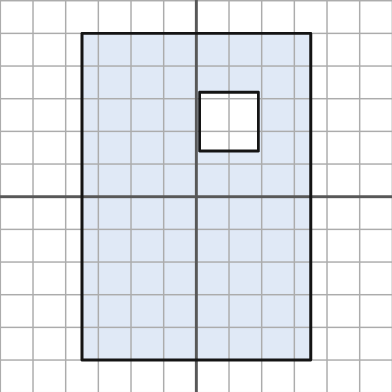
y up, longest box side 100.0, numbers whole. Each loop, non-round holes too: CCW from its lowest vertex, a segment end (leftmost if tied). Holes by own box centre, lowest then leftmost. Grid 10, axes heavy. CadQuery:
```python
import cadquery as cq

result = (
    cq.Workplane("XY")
    .moveTo(-35.0, -50.0)
    .lineTo(35.0, -50.0)
    .lineTo(35.0, 50.0)
    .lineTo(-35.0, 50.0)
    .close()
    .moveTo(1.0, 14.0)
    .lineTo(19.0, 14.0)
    .lineTo(19.0, 32.0)
    .lineTo(1.0, 32.0)
    .close()
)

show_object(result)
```